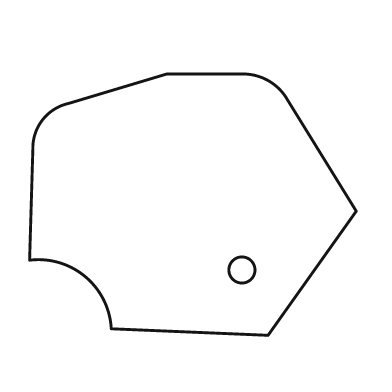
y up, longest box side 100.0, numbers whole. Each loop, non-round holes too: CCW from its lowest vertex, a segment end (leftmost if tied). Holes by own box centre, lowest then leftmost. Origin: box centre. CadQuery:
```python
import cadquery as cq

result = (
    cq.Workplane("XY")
    .moveTo(23.0, -40.0)
    .lineTo(50.0, -2.0)
    .lineTo(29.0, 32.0)
    .threePointArc((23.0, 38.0), (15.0, 40.0))
    .lineTo(-8.0, 40.0)
    .lineTo(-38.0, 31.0)
    .threePointArc((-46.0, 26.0), (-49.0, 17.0))
    .lineTo(-50.0, -17.0)
    .threePointArc((-33.0, -22.0), (-25.0, -38.0))
    .close()
    .moveTo(15.0, -20.0)
    .circle(4.0)
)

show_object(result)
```